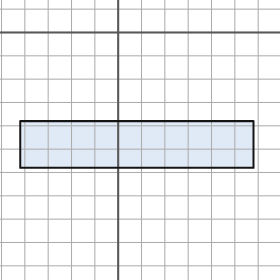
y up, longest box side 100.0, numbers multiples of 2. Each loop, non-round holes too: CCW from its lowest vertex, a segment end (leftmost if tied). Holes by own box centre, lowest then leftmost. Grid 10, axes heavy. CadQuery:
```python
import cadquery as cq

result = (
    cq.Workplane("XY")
    .moveTo(-42.0, -58.0)
    .lineTo(58.0, -58.0)
    .lineTo(58.0, -38.0)
    .lineTo(-42.0, -38.0)
    .close()
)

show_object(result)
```